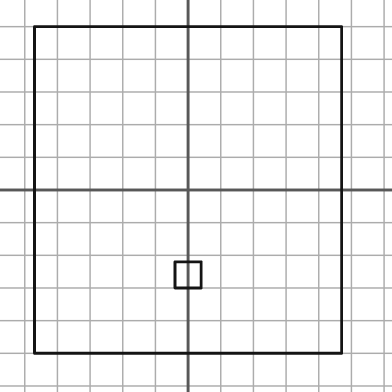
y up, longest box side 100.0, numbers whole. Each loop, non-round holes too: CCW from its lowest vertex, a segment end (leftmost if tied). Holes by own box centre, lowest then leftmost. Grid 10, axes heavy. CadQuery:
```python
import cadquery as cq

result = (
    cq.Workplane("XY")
    .moveTo(-47.0, -50.0)
    .lineTo(47.0, -50.0)
    .lineTo(47.0, 50.0)
    .lineTo(-47.0, 50.0)
    .close()
    .moveTo(-4.0, -30.0)
    .lineTo(4.0, -30.0)
    .lineTo(4.0, -22.0)
    .lineTo(-4.0, -22.0)
    .close()
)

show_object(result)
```